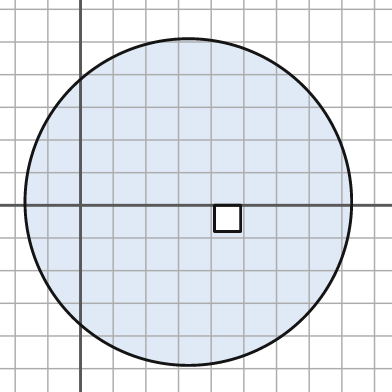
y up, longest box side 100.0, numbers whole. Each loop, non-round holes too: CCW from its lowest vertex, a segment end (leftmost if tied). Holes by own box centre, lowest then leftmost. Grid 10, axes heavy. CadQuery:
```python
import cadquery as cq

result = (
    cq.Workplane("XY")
    .moveTo(33.0, 1.0)
    .circle(50.0)
    .moveTo(41.0, -8.0)
    .lineTo(49.0, -8.0)
    .lineTo(49.0, 0.0)
    .lineTo(41.0, 0.0)
    .close()
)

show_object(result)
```